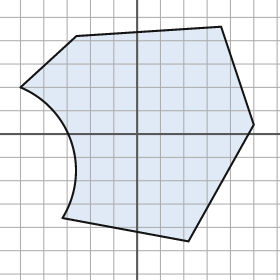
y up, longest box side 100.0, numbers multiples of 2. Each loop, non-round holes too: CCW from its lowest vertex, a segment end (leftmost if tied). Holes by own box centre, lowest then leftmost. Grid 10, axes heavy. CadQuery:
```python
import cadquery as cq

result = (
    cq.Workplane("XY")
    .moveTo(22.0, -46.0)
    .lineTo(50.0, 4.0)
    .lineTo(36.0, 46.0)
    .lineTo(-26.0, 42.0)
    .lineTo(-50.0, 20.0)
    .threePointArc((-28.0, -4.0), (-32.0, -36.0))
    .close()
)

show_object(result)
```